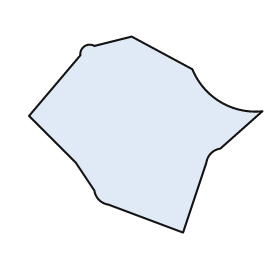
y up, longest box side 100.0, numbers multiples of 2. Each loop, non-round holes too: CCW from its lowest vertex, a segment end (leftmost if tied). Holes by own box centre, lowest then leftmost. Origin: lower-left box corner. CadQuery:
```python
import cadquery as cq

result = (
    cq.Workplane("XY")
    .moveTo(66.0, 0.0)
    .lineTo(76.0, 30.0)
    .threePointArc((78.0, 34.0), (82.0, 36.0))
    .lineTo(100.0, 52.0)
    .threePointArc((82.0, 56.0), (70.0, 70.0))
    .lineTo(44.0, 84.0)
    .lineTo(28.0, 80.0)
    .threePointArc((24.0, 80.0), (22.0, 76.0))
    .lineTo(0.0, 50.0)
    .lineTo(20.0, 30.0)
    .lineTo(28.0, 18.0)
    .threePointArc((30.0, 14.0), (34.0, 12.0))
    .close()
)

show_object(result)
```